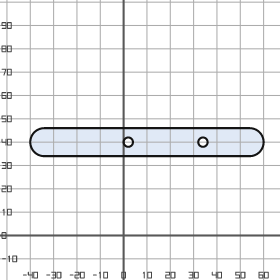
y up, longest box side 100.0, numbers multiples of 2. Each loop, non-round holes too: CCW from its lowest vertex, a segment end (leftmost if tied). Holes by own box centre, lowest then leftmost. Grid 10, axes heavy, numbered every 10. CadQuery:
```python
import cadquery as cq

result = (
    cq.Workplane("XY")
    .moveTo(-34.0, 34.0)
    .lineTo(54.0, 34.0)
    .threePointArc((60.0, 40.0), (54.0, 46.0))
    .lineTo(-34.0, 46.0)
    .threePointArc((-40.0, 40.0), (-34.0, 34.0))
    .close()
    .moveTo(2.0, 40.0)
    .circle(2.0)
    .moveTo(34.0, 40.0)
    .circle(2.0)
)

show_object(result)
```